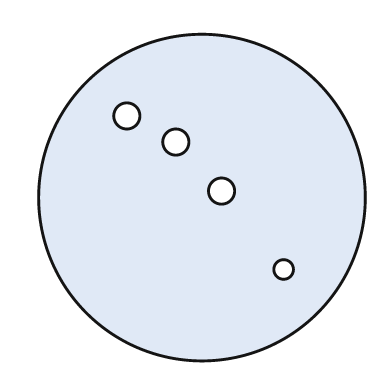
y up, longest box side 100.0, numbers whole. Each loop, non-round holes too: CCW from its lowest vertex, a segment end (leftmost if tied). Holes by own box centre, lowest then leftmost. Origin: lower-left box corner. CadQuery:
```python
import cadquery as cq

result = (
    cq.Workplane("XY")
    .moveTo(50.0, 50.0)
    .circle(50.0)
    .moveTo(75.0, 28.0)
    .circle(3.0)
    .moveTo(56.0, 52.0)
    .circle(4.0)
    .moveTo(42.0, 67.0)
    .circle(4.0)
    .moveTo(27.0, 75.0)
    .circle(4.0)
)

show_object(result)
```